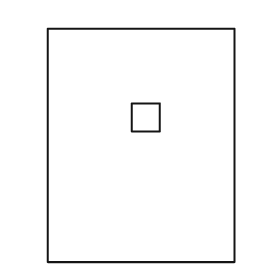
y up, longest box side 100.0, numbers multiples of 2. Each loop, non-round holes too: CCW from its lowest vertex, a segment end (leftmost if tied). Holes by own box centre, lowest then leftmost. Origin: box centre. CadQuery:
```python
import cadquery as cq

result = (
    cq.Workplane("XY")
    .moveTo(-40.0, -50.0)
    .lineTo(40.0, -50.0)
    .lineTo(40.0, 50.0)
    .lineTo(-40.0, 50.0)
    .close()
    .moveTo(-4.0, 6.0)
    .lineTo(8.0, 6.0)
    .lineTo(8.0, 18.0)
    .lineTo(-4.0, 18.0)
    .close()
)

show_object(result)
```